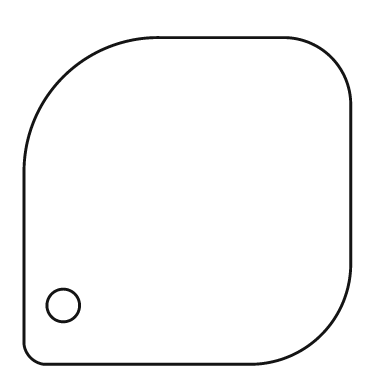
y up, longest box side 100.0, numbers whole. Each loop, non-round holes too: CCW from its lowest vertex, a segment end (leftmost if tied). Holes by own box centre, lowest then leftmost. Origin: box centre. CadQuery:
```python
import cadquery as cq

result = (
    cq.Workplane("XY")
    .moveTo(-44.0, -50.0)
    .lineTo(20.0, -50.0)
    .threePointArc((41.0, -41.0), (50.0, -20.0))
    .lineTo(50.0, 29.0)
    .threePointArc((44.0, 44.0), (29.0, 50.0))
    .lineTo(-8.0, 50.0)
    .threePointArc((-38.0, 38.0), (-50.0, 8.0))
    .lineTo(-50.0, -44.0)
    .threePointArc((-48.0, -48.0), (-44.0, -50.0))
    .close()
    .moveTo(-38.0, -32.0)
    .circle(5.0)
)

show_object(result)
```